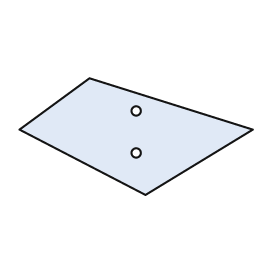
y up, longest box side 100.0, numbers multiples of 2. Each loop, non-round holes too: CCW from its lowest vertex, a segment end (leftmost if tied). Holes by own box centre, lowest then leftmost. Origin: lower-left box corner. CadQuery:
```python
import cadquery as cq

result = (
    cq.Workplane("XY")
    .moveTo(54.0, 0.0)
    .lineTo(100.0, 28.0)
    .lineTo(30.0, 50.0)
    .lineTo(0.0, 28.0)
    .close()
    .moveTo(50.0, 18.0)
    .circle(2.0)
    .moveTo(50.0, 36.0)
    .circle(2.0)
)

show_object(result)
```